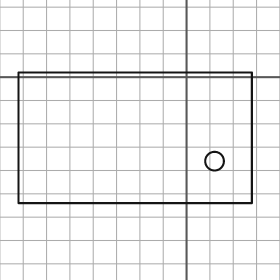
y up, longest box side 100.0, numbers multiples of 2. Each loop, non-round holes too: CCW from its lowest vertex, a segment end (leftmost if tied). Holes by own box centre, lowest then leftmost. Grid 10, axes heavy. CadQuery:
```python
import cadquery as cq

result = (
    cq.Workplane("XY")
    .moveTo(-72.0, -54.0)
    .lineTo(28.0, -54.0)
    .lineTo(28.0, 2.0)
    .lineTo(-72.0, 2.0)
    .close()
    .moveTo(12.0, -36.0)
    .circle(4.0)
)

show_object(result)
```